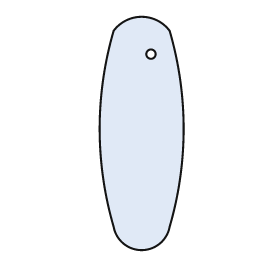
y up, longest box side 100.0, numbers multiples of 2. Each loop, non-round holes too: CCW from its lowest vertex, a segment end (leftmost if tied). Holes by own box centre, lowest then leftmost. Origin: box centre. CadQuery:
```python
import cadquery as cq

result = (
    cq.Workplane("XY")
    .moveTo(-12.0, -40.0)
    .threePointArc((0.0, -50.0), (12.0, -40.0))
    .threePointArc((18.0, 2.0), (12.0, 44.0))
    .threePointArc((0.0, 50.0), (-12.0, 44.0))
    .threePointArc((-18.0, 2.0), (-12.0, -40.0))
    .close()
    .moveTo(4.0, 34.0)
    .circle(2.0)
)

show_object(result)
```